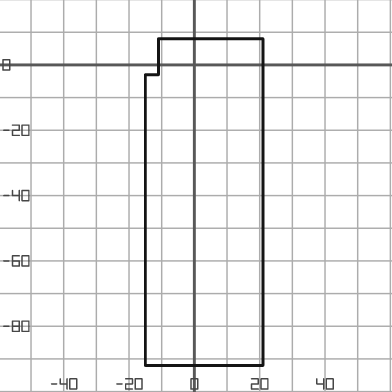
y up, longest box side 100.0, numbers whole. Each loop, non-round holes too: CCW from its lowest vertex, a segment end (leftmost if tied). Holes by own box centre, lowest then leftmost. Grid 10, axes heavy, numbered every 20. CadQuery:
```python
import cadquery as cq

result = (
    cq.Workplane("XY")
    .moveTo(-15.0, -92.0)
    .lineTo(21.0, -92.0)
    .lineTo(21.0, 8.0)
    .lineTo(-11.0, 8.0)
    .lineTo(-11.0, -3.0)
    .lineTo(-15.0, -3.0)
    .close()
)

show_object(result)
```